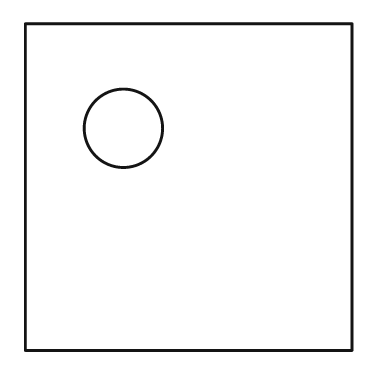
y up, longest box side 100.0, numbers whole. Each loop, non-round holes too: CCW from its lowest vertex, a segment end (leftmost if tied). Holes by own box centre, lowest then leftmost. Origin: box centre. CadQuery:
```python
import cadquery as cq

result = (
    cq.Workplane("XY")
    .moveTo(-50.0, -50.0)
    .lineTo(50.0, -50.0)
    .lineTo(50.0, 50.0)
    .lineTo(-50.0, 50.0)
    .close()
    .moveTo(-20.0, 18.0)
    .circle(12.0)
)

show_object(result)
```